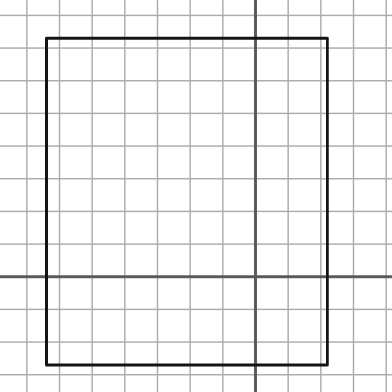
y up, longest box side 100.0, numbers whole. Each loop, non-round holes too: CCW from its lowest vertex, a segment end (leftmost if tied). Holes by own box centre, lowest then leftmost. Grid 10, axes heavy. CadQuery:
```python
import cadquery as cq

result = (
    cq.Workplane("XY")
    .moveTo(-64.0, -27.0)
    .lineTo(22.0, -27.0)
    .lineTo(22.0, 73.0)
    .lineTo(-64.0, 73.0)
    .close()
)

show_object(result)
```